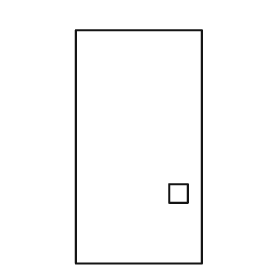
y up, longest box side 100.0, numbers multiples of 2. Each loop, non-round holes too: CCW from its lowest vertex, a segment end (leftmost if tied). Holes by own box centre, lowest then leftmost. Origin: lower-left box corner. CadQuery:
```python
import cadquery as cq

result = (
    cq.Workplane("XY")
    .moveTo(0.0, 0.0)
    .lineTo(54.0, 0.0)
    .lineTo(54.0, 100.0)
    .lineTo(0.0, 100.0)
    .close()
    .moveTo(40.0, 26.0)
    .lineTo(48.0, 26.0)
    .lineTo(48.0, 34.0)
    .lineTo(40.0, 34.0)
    .close()
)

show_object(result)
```